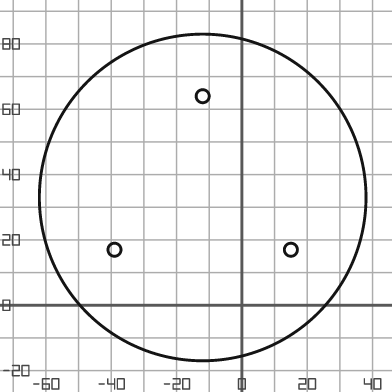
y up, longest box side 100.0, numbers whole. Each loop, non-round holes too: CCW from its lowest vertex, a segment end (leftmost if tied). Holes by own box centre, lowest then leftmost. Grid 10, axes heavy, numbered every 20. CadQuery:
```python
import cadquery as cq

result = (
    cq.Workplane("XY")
    .moveTo(-12.0, 33.0)
    .circle(50.0)
    .moveTo(-39.0, 17.0)
    .circle(2.0)
    .moveTo(15.0, 17.0)
    .circle(2.0)
    .moveTo(-12.0, 64.0)
    .circle(2.0)
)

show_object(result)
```